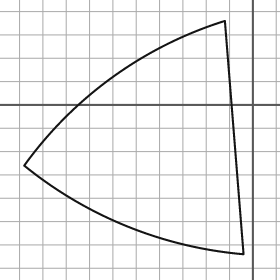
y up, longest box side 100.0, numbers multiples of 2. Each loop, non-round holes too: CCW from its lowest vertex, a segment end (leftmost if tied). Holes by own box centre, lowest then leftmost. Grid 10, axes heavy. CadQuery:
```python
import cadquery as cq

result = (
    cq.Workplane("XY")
    .moveTo(-4.0, -64.0)
    .lineTo(-12.0, 36.0)
    .threePointArc((-60.0, 12.0), (-98.0, -26.0))
    .threePointArc((-54.0, -52.0), (-4.0, -64.0))
    .close()
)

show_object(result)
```